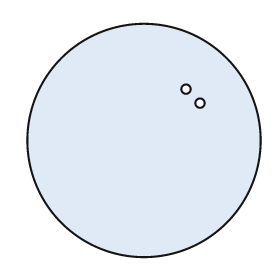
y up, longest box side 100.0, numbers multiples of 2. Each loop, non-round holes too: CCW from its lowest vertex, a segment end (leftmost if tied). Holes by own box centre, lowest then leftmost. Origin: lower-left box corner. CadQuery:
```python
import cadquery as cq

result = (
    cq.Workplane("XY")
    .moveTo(50.0, 50.0)
    .circle(50.0)
    .moveTo(74.0, 66.0)
    .circle(2.0)
    .moveTo(68.0, 72.0)
    .circle(2.0)
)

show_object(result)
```